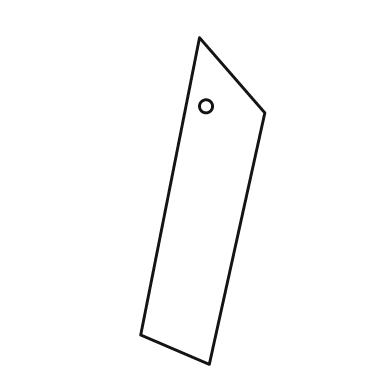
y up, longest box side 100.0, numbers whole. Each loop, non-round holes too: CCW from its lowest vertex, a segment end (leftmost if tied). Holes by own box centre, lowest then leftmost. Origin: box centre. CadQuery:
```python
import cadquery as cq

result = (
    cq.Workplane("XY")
    .moveTo(2.0, -50.0)
    .lineTo(19.0, 27.0)
    .lineTo(-1.0, 50.0)
    .lineTo(-19.0, -41.0)
    .close()
    .moveTo(1.0, 29.0)
    .circle(2.0)
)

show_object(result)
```